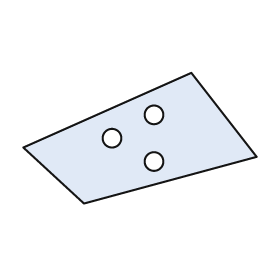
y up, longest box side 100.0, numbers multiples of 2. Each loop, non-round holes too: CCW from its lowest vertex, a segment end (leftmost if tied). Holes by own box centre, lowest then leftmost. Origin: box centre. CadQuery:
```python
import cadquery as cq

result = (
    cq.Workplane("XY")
    .moveTo(-24.0, -28.0)
    .lineTo(50.0, -8.0)
    .lineTo(22.0, 28.0)
    .lineTo(-50.0, -4.0)
    .close()
    .moveTo(6.0, -10.0)
    .circle(4.0)
    .moveTo(-12.0, 0.0)
    .circle(4.0)
    .moveTo(6.0, 10.0)
    .circle(4.0)
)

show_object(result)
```